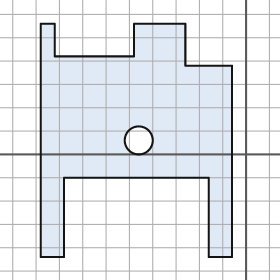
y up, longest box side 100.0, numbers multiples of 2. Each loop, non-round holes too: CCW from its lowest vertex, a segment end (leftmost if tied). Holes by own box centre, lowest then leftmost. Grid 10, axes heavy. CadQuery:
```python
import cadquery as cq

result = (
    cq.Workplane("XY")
    .moveTo(-88.0, -44.0)
    .lineTo(-78.0, -44.0)
    .lineTo(-78.0, -10.0)
    .lineTo(-16.0, -10.0)
    .lineTo(-16.0, -44.0)
    .lineTo(-6.0, -44.0)
    .lineTo(-6.0, 38.0)
    .lineTo(-26.0, 38.0)
    .lineTo(-26.0, 56.0)
    .lineTo(-48.0, 56.0)
    .lineTo(-48.0, 42.0)
    .lineTo(-82.0, 42.0)
    .lineTo(-82.0, 56.0)
    .lineTo(-88.0, 56.0)
    .close()
    .moveTo(-46.0, 6.0)
    .circle(6.0)
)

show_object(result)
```